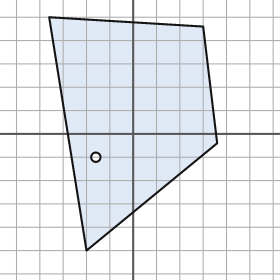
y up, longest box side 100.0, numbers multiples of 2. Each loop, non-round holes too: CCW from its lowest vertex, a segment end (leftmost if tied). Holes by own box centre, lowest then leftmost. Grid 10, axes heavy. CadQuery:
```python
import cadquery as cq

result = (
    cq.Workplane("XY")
    .moveTo(-20.0, -50.0)
    .lineTo(36.0, -4.0)
    .lineTo(30.0, 46.0)
    .lineTo(-36.0, 50.0)
    .close()
    .moveTo(-16.0, -10.0)
    .circle(2.0)
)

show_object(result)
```